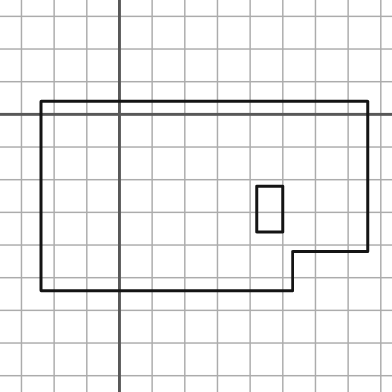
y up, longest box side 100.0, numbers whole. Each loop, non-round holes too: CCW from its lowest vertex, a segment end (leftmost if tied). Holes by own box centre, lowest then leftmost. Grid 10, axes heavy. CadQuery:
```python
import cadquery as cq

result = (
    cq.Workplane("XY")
    .moveTo(-24.0, -54.0)
    .lineTo(53.0, -54.0)
    .lineTo(53.0, -42.0)
    .lineTo(76.0, -42.0)
    .lineTo(76.0, 4.0)
    .lineTo(-24.0, 4.0)
    .close()
    .moveTo(42.0, -36.0)
    .lineTo(50.0, -36.0)
    .lineTo(50.0, -22.0)
    .lineTo(42.0, -22.0)
    .close()
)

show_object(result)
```